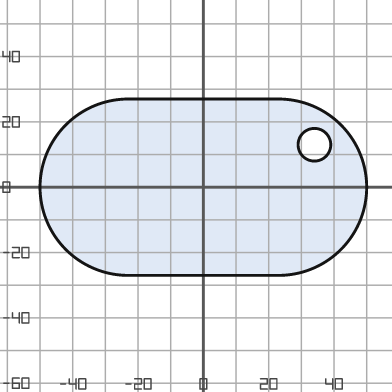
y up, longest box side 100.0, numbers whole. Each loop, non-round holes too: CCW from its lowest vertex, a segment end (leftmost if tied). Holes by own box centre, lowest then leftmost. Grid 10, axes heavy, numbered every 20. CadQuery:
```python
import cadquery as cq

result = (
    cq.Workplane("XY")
    .moveTo(-23.0, -27.0)
    .lineTo(23.0, -27.0)
    .threePointArc((50.0, 0.0), (23.0, 27.0))
    .lineTo(-23.0, 27.0)
    .threePointArc((-50.0, 0.0), (-23.0, -27.0))
    .close()
    .moveTo(34.0, 13.0)
    .circle(5.0)
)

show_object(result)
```